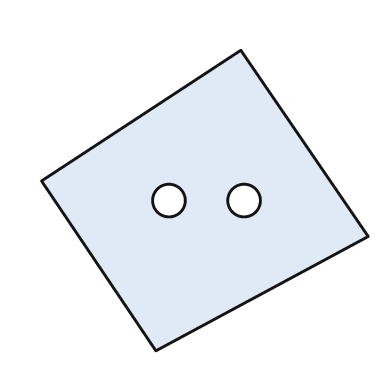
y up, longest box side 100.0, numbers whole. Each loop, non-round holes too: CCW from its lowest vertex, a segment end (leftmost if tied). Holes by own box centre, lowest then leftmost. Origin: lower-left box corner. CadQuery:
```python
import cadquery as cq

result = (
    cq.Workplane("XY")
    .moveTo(35.0, 0.0)
    .lineTo(100.0, 35.0)
    .lineTo(61.0, 92.0)
    .lineTo(0.0, 52.0)
    .close()
    .moveTo(39.0, 46.0)
    .circle(5.0)
    .moveTo(62.0, 46.0)
    .circle(5.0)
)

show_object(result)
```